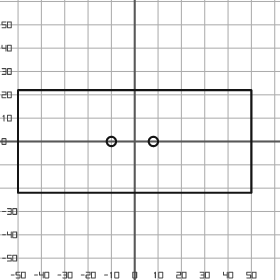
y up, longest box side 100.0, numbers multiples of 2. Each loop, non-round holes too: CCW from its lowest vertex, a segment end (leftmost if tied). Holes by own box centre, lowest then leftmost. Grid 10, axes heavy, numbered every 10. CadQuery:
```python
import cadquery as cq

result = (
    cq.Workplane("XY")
    .moveTo(-50.0, -22.0)
    .lineTo(50.0, -22.0)
    .lineTo(50.0, 22.0)
    .lineTo(-50.0, 22.0)
    .close()
    .moveTo(-10.0, 0.0)
    .circle(2.0)
    .moveTo(8.0, 0.0)
    .circle(2.0)
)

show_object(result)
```